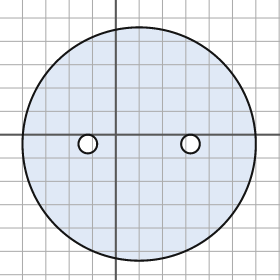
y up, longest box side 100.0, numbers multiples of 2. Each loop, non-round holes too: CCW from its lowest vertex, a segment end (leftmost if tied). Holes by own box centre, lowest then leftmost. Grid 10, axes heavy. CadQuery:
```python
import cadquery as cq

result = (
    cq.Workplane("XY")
    .moveTo(10.0, -4.0)
    .circle(50.0)
    .moveTo(-12.0, -4.0)
    .circle(4.0)
    .moveTo(32.0, -4.0)
    .circle(4.0)
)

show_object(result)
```